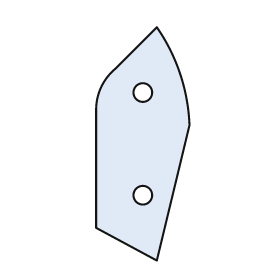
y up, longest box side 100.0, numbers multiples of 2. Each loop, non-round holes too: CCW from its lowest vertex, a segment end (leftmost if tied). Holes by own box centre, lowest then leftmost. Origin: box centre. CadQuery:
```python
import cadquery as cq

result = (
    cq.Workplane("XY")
    .moveTo(6.0, -50.0)
    .lineTo(20.0, 8.0)
    .threePointArc((16.0, 30.0), (6.0, 50.0))
    .lineTo(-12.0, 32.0)
    .threePointArc((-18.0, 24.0), (-20.0, 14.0))
    .lineTo(-20.0, -36.0)
    .close()
    .moveTo(0.0, -22.0)
    .circle(4.0)
    .moveTo(0.0, 22.0)
    .circle(4.0)
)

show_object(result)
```